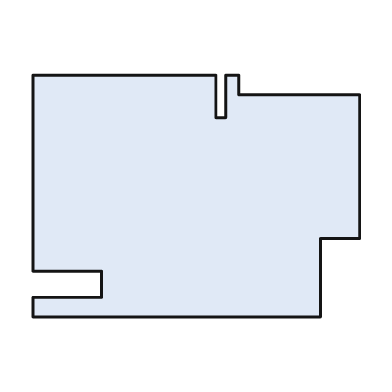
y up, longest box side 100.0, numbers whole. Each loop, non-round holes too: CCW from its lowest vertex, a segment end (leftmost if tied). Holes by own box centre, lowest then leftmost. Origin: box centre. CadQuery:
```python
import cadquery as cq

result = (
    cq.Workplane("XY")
    .moveTo(-50.0, -37.0)
    .lineTo(38.0, -37.0)
    .lineTo(38.0, -13.0)
    .lineTo(50.0, -13.0)
    .lineTo(50.0, 31.0)
    .lineTo(13.0, 31.0)
    .lineTo(13.0, 37.0)
    .lineTo(9.0, 37.0)
    .lineTo(9.0, 24.0)
    .lineTo(6.0, 24.0)
    .lineTo(6.0, 37.0)
    .lineTo(-50.0, 37.0)
    .lineTo(-50.0, -23.0)
    .lineTo(-29.0, -23.0)
    .lineTo(-29.0, -31.0)
    .lineTo(-50.0, -31.0)
    .close()
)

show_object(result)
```